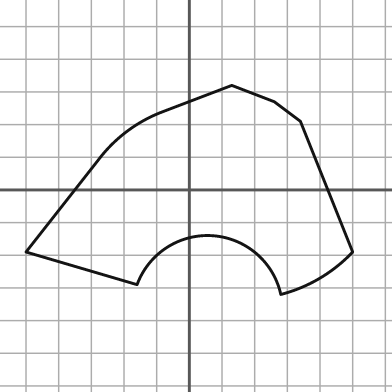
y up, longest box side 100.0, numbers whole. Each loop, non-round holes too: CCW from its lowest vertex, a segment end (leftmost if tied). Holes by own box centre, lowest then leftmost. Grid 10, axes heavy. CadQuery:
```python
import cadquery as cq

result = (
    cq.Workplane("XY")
    .moveTo(28.0, -32.0)
    .threePointArc((40.0, -27.0), (50.0, -19.0))
    .lineTo(34.0, 21.0)
    .lineTo(26.0, 27.0)
    .lineTo(13.0, 32.0)
    .lineTo(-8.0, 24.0)
    .threePointArc((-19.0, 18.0), (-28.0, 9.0))
    .lineTo(-50.0, -19.0)
    .lineTo(-16.0, -29.0)
    .threePointArc((7.0, -14.0), (28.0, -32.0))
    .close()
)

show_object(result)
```